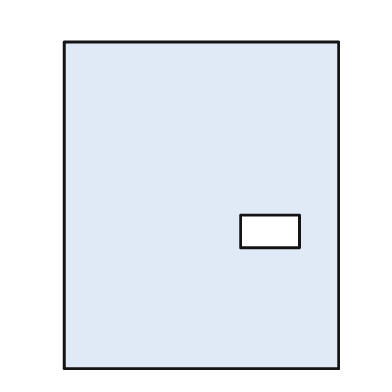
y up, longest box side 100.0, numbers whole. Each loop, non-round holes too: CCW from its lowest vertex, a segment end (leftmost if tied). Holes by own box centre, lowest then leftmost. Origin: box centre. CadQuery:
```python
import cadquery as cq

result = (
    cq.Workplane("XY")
    .moveTo(-42.0, -50.0)
    .lineTo(42.0, -50.0)
    .lineTo(42.0, 50.0)
    .lineTo(-42.0, 50.0)
    .close()
    .moveTo(12.0, -13.0)
    .lineTo(30.0, -13.0)
    .lineTo(30.0, -3.0)
    .lineTo(12.0, -3.0)
    .close()
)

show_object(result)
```